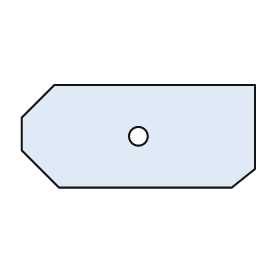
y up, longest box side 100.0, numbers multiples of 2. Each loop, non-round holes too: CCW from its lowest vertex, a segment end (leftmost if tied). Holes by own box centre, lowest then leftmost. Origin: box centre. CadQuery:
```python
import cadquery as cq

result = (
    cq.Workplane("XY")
    .moveTo(-34.0, -22.0)
    .lineTo(40.0, -22.0)
    .lineTo(50.0, -14.0)
    .lineTo(50.0, 22.0)
    .lineTo(-36.0, 22.0)
    .lineTo(-50.0, 8.0)
    .lineTo(-50.0, -6.0)
    .close()
    .moveTo(0.0, 0.0)
    .circle(4.0)
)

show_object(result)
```